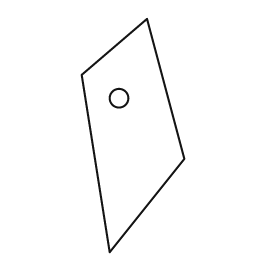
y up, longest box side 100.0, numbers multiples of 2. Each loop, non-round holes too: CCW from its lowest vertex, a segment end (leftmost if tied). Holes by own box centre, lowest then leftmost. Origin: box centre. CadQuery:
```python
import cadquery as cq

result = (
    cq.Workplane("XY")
    .moveTo(-10.0, -50.0)
    .lineTo(22.0, -10.0)
    .lineTo(6.0, 50.0)
    .lineTo(-22.0, 26.0)
    .close()
    .moveTo(-6.0, 16.0)
    .circle(4.0)
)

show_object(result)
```